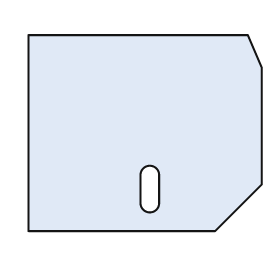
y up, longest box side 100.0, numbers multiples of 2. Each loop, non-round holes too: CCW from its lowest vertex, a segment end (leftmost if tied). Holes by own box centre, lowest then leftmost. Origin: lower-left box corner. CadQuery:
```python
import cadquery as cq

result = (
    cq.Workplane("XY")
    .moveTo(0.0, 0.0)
    .lineTo(80.0, 0.0)
    .lineTo(100.0, 20.0)
    .lineTo(100.0, 70.0)
    .lineTo(94.0, 84.0)
    .lineTo(0.0, 84.0)
    .close()
    .moveTo(48.0, 12.0)
    .threePointArc((52.0, 8.0), (56.0, 12.0))
    .lineTo(56.0, 24.0)
    .threePointArc((52.0, 28.0), (48.0, 24.0))
    .close()
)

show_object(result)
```